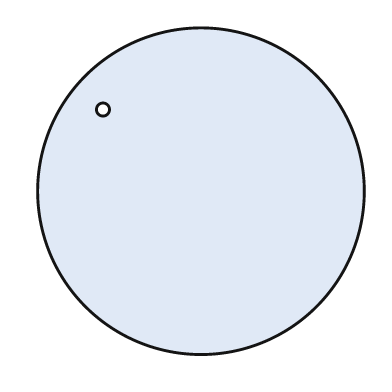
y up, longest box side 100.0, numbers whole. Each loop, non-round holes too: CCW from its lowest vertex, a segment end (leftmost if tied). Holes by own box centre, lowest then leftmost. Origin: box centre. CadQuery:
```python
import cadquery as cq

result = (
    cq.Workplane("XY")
    .moveTo(0.0, 0.0)
    .circle(50.0)
    .moveTo(-30.0, 25.0)
    .circle(2.0)
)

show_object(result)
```